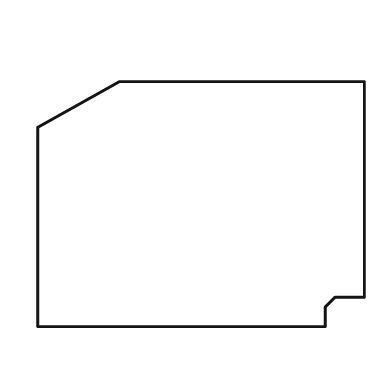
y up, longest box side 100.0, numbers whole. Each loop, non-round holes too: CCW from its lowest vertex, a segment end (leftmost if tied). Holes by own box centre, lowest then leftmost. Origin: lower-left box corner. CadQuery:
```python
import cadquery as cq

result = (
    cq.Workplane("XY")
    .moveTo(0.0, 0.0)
    .lineTo(88.0, 0.0)
    .lineTo(88.0, 6.0)
    .lineTo(91.0, 9.0)
    .lineTo(100.0, 9.0)
    .lineTo(100.0, 75.0)
    .lineTo(25.0, 75.0)
    .lineTo(0.0, 61.0)
    .close()
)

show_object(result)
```